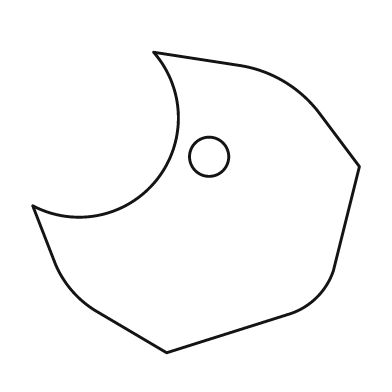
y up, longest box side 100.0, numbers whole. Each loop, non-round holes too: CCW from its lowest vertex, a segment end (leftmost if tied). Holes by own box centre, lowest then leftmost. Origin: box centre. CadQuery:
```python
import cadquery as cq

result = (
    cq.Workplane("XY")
    .moveTo(-9.0, -46.0)
    .lineTo(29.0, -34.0)
    .threePointArc((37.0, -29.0), (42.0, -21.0))
    .lineTo(50.0, 11.0)
    .lineTo(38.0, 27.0)
    .threePointArc((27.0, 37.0), (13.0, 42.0))
    .lineTo(-13.0, 46.0)
    .threePointArc((-12.0, 7.0), (-50.0, -1.0))
    .lineTo(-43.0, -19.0)
    .threePointArc((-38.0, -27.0), (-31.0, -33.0))
    .close()
    .moveTo(4.0, 14.0)
    .circle(6.0)
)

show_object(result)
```